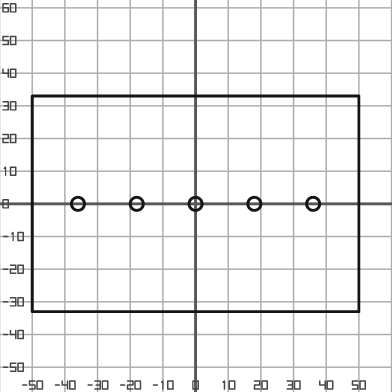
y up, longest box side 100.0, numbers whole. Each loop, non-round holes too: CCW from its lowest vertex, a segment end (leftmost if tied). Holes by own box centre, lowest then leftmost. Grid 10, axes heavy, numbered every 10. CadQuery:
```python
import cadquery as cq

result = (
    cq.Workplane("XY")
    .moveTo(-50.0, -33.0)
    .lineTo(50.0, -33.0)
    .lineTo(50.0, 33.0)
    .lineTo(-50.0, 33.0)
    .close()
    .moveTo(-36.0, 0.0)
    .circle(2.0)
    .moveTo(-18.0, 0.0)
    .circle(2.0)
    .moveTo(0.0, 0.0)
    .circle(2.0)
    .moveTo(18.0, 0.0)
    .circle(2.0)
    .moveTo(36.0, 0.0)
    .circle(2.0)
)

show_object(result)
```